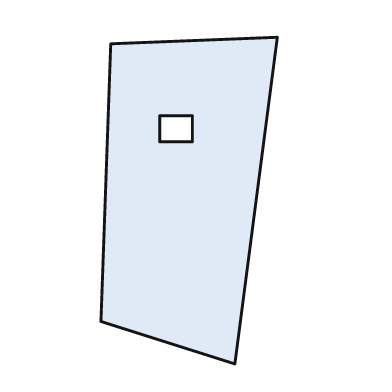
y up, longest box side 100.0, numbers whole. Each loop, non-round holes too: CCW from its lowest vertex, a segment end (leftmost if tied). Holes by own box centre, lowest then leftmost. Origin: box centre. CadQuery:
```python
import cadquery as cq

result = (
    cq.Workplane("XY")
    .moveTo(14.0, -50.0)
    .lineTo(27.0, 50.0)
    .lineTo(-24.0, 48.0)
    .lineTo(-27.0, -37.0)
    .close()
    .moveTo(-9.0, 18.0)
    .lineTo(1.0, 18.0)
    .lineTo(1.0, 26.0)
    .lineTo(-9.0, 26.0)
    .close()
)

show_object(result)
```